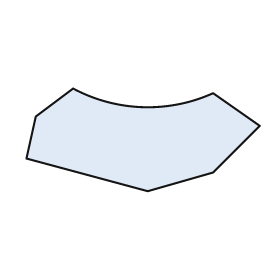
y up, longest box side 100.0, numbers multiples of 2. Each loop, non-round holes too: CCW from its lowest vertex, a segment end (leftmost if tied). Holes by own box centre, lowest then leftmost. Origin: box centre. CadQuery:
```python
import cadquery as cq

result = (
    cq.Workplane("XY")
    .moveTo(2.0, -22.0)
    .lineTo(30.0, -14.0)
    .lineTo(50.0, 6.0)
    .lineTo(30.0, 20.0)
    .threePointArc((0.0, 14.0), (-30.0, 22.0))
    .lineTo(-46.0, 10.0)
    .lineTo(-50.0, -8.0)
    .close()
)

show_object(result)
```